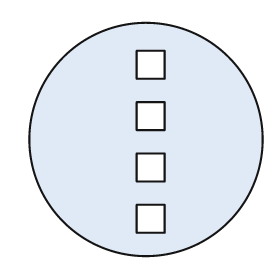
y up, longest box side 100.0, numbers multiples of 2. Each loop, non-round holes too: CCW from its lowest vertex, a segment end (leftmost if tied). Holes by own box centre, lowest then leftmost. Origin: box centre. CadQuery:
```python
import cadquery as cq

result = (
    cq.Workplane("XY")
    .moveTo(0.0, 0.0)
    .circle(50.0)
    .moveTo(-4.0, -40.0)
    .lineTo(8.0, -40.0)
    .lineTo(8.0, -28.0)
    .lineTo(-4.0, -28.0)
    .close()
    .moveTo(-4.0, -18.0)
    .lineTo(8.0, -18.0)
    .lineTo(8.0, -6.0)
    .lineTo(-4.0, -6.0)
    .close()
    .moveTo(-4.0, 4.0)
    .lineTo(8.0, 4.0)
    .lineTo(8.0, 16.0)
    .lineTo(-4.0, 16.0)
    .close()
    .moveTo(-4.0, 26.0)
    .lineTo(8.0, 26.0)
    .lineTo(8.0, 38.0)
    .lineTo(-4.0, 38.0)
    .close()
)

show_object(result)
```